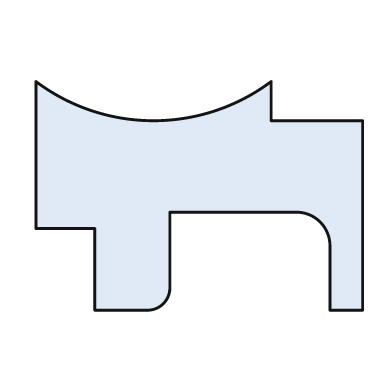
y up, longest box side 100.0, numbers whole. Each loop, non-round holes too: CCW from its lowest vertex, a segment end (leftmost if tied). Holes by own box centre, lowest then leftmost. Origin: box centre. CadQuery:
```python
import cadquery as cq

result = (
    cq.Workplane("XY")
    .moveTo(-32.0, -35.0)
    .lineTo(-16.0, -35.0)
    .threePointArc((-11.0, -33.0), (-9.0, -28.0))
    .lineTo(-9.0, -5.0)
    .lineTo(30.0, -5.0)
    .threePointArc((37.0, -8.0), (40.0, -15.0))
    .lineTo(40.0, -35.0)
    .lineTo(50.0, -35.0)
    .lineTo(50.0, 23.0)
    .lineTo(22.0, 23.0)
    .lineTo(22.0, 35.0)
    .threePointArc((-14.0, 23.0), (-50.0, 35.0))
    .lineTo(-50.0, -10.0)
    .lineTo(-32.0, -10.0)
    .close()
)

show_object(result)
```